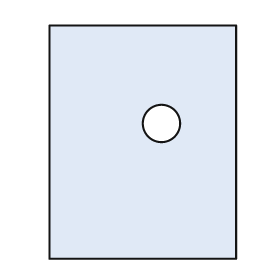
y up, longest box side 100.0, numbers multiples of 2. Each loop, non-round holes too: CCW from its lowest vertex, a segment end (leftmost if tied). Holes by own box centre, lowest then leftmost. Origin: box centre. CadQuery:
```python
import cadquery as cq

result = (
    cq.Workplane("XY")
    .moveTo(-40.0, -50.0)
    .lineTo(40.0, -50.0)
    .lineTo(40.0, 50.0)
    .lineTo(-40.0, 50.0)
    .close()
    .moveTo(8.0, 8.0)
    .circle(8.0)
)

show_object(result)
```